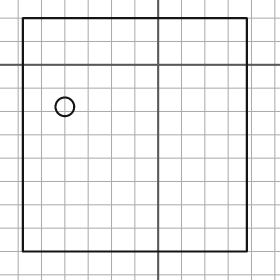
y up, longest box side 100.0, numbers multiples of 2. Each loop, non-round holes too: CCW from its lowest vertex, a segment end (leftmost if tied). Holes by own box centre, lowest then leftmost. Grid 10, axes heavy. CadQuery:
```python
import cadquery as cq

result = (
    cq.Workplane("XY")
    .moveTo(-58.0, -80.0)
    .lineTo(38.0, -80.0)
    .lineTo(38.0, 20.0)
    .lineTo(-58.0, 20.0)
    .close()
    .moveTo(-40.0, -18.0)
    .circle(4.0)
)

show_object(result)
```